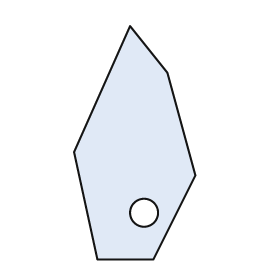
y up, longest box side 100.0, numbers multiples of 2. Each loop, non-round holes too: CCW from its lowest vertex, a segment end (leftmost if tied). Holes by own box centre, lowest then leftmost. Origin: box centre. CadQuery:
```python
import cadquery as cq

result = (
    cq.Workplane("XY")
    .moveTo(-16.0, -50.0)
    .lineTo(8.0, -50.0)
    .lineTo(26.0, -14.0)
    .lineTo(14.0, 30.0)
    .lineTo(-2.0, 50.0)
    .lineTo(-26.0, -4.0)
    .close()
    .moveTo(4.0, -30.0)
    .circle(6.0)
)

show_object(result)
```